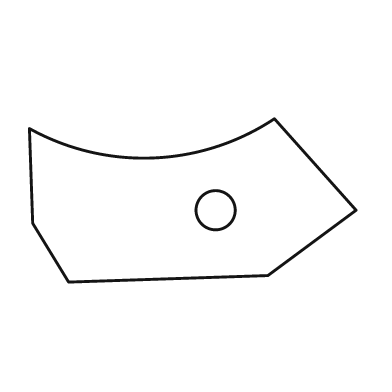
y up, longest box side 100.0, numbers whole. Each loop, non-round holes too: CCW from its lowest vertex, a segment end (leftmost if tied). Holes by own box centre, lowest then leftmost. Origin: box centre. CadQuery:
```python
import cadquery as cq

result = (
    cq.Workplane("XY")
    .moveTo(-38.0, -25.0)
    .lineTo(23.0, -23.0)
    .lineTo(50.0, -3.0)
    .lineTo(25.0, 25.0)
    .threePointArc((-12.0, 13.0), (-50.0, 22.0))
    .lineTo(-49.0, -7.0)
    .close()
    .moveTo(7.0, -3.0)
    .circle(6.0)
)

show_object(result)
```